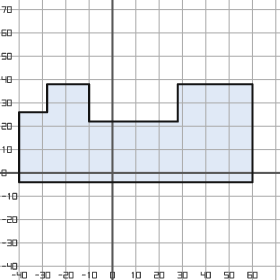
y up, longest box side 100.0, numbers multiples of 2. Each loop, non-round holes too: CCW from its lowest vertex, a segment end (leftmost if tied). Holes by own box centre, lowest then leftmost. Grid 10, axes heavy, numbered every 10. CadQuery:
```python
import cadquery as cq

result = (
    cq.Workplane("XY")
    .moveTo(-40.0, -4.0)
    .lineTo(60.0, -4.0)
    .lineTo(60.0, 38.0)
    .lineTo(28.0, 38.0)
    .lineTo(28.0, 22.0)
    .lineTo(-10.0, 22.0)
    .lineTo(-10.0, 38.0)
    .lineTo(-28.0, 38.0)
    .lineTo(-28.0, 26.0)
    .lineTo(-40.0, 26.0)
    .close()
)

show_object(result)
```